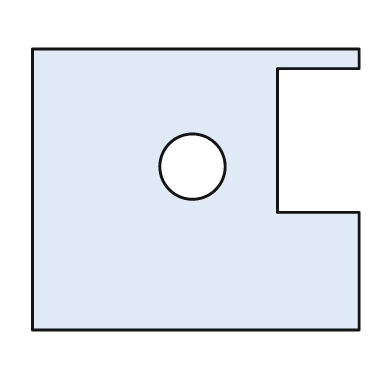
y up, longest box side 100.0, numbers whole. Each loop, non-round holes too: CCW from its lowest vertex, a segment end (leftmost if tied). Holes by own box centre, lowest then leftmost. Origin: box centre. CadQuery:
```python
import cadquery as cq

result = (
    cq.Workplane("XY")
    .moveTo(-50.0, -43.0)
    .lineTo(50.0, -43.0)
    .lineTo(50.0, -7.0)
    .lineTo(25.0, -7.0)
    .lineTo(25.0, 37.0)
    .lineTo(50.0, 37.0)
    .lineTo(50.0, 43.0)
    .lineTo(-50.0, 43.0)
    .close()
    .moveTo(-1.0, 7.0)
    .circle(10.0)
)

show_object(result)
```